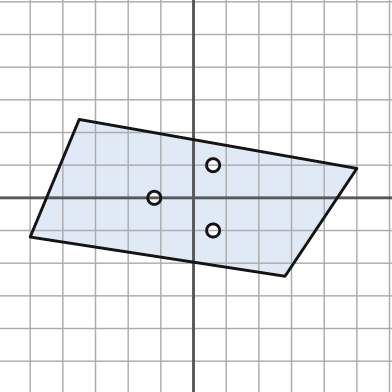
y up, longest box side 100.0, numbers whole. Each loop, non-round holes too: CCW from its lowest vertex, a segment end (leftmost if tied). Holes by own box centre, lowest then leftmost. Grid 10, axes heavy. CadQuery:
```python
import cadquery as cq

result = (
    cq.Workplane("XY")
    .moveTo(28.0, -24.0)
    .lineTo(50.0, 9.0)
    .lineTo(-35.0, 24.0)
    .lineTo(-50.0, -12.0)
    .close()
    .moveTo(6.0, -10.0)
    .circle(2.0)
    .moveTo(-12.0, 0.0)
    .circle(2.0)
    .moveTo(6.0, 10.0)
    .circle(2.0)
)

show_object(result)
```